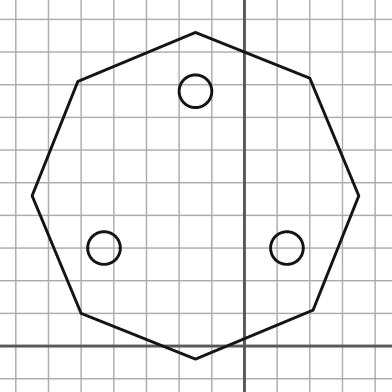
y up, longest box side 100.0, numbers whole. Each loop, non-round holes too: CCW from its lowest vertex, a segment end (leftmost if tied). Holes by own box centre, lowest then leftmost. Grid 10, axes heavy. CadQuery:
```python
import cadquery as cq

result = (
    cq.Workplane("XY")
    .moveTo(-15.0, -4.0)
    .lineTo(21.0, 11.0)
    .lineTo(35.0, 46.0)
    .lineTo(20.0, 82.0)
    .lineTo(-15.0, 96.0)
    .lineTo(-51.0, 81.0)
    .lineTo(-65.0, 46.0)
    .lineTo(-50.0, 10.0)
    .close()
    .moveTo(-43.0, 30.0)
    .circle(5.0)
    .moveTo(13.0, 30.0)
    .circle(5.0)
    .moveTo(-15.0, 78.0)
    .circle(5.0)
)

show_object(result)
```